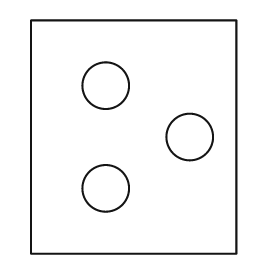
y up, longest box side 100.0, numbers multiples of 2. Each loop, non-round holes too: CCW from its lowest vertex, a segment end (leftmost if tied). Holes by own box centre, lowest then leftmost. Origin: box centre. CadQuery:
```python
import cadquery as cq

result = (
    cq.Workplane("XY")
    .moveTo(-44.0, -50.0)
    .lineTo(44.0, -50.0)
    .lineTo(44.0, 50.0)
    .lineTo(-44.0, 50.0)
    .close()
    .moveTo(-12.0, -22.0)
    .circle(10.0)
    .moveTo(24.0, 0.0)
    .circle(10.0)
    .moveTo(-12.0, 22.0)
    .circle(10.0)
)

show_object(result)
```